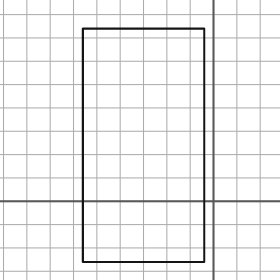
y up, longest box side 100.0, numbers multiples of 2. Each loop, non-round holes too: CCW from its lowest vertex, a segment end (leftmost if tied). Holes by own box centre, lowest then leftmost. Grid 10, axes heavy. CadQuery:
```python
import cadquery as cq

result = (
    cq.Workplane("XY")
    .moveTo(-56.0, -26.0)
    .lineTo(-4.0, -26.0)
    .lineTo(-4.0, 74.0)
    .lineTo(-56.0, 74.0)
    .close()
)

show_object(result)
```